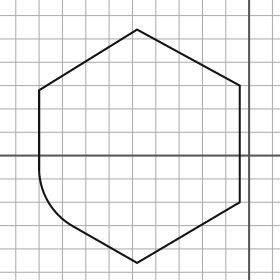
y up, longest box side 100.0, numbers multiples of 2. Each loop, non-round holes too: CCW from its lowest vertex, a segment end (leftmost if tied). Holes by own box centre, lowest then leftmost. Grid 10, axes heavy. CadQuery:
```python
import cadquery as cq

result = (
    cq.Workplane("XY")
    .moveTo(-48.0, -46.0)
    .lineTo(-4.0, -20.0)
    .lineTo(-4.0, 30.0)
    .lineTo(-48.0, 54.0)
    .lineTo(-90.0, 28.0)
    .lineTo(-90.0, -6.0)
    .threePointArc((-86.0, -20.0), (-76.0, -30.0))
    .close()
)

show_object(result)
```